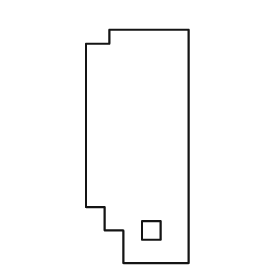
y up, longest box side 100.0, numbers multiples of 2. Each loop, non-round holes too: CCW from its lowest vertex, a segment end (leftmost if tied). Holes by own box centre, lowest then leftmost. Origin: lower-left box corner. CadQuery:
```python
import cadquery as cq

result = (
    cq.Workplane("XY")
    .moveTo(16.0, 0.0)
    .lineTo(44.0, 0.0)
    .lineTo(44.0, 100.0)
    .lineTo(10.0, 100.0)
    .lineTo(10.0, 94.0)
    .lineTo(0.0, 94.0)
    .lineTo(0.0, 24.0)
    .lineTo(8.0, 24.0)
    .lineTo(8.0, 14.0)
    .lineTo(16.0, 14.0)
    .close()
    .moveTo(24.0, 10.0)
    .lineTo(32.0, 10.0)
    .lineTo(32.0, 18.0)
    .lineTo(24.0, 18.0)
    .close()
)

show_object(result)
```